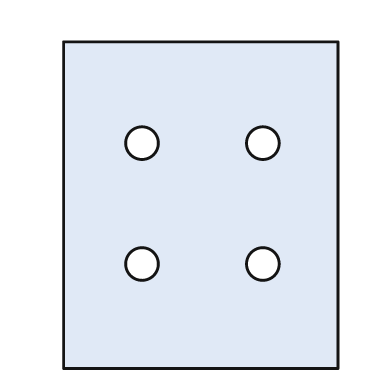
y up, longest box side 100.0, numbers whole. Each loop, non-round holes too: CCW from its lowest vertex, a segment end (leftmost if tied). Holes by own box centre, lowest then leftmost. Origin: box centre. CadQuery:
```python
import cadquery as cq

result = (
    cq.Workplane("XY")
    .moveTo(-42.0, -50.0)
    .lineTo(42.0, -50.0)
    .lineTo(42.0, 50.0)
    .lineTo(-42.0, 50.0)
    .close()
    .moveTo(-18.0, -18.0)
    .circle(5.0)
    .moveTo(19.0, -18.0)
    .circle(5.0)
    .moveTo(-18.0, 19.0)
    .circle(5.0)
    .moveTo(19.0, 19.0)
    .circle(5.0)
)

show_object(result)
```